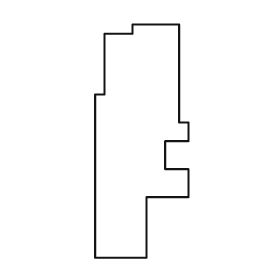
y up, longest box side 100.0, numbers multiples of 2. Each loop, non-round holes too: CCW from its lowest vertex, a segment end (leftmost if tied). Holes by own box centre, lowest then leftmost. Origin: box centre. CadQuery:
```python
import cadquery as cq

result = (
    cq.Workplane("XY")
    .moveTo(-20.0, -50.0)
    .lineTo(2.0, -50.0)
    .lineTo(2.0, -24.0)
    .lineTo(20.0, -24.0)
    .lineTo(20.0, -12.0)
    .lineTo(10.0, -12.0)
    .lineTo(10.0, 0.0)
    .lineTo(20.0, 0.0)
    .lineTo(20.0, 8.0)
    .lineTo(16.0, 8.0)
    .lineTo(16.0, 50.0)
    .lineTo(-4.0, 50.0)
    .lineTo(-4.0, 46.0)
    .lineTo(-16.0, 46.0)
    .lineTo(-16.0, 20.0)
    .lineTo(-20.0, 20.0)
    .close()
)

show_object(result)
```